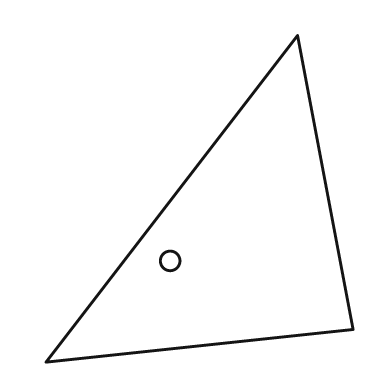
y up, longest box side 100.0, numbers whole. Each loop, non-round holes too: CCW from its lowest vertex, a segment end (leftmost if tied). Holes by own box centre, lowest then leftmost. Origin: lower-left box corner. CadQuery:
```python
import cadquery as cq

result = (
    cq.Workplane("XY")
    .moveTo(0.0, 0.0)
    .lineTo(94.0, 10.0)
    .lineTo(77.0, 100.0)
    .close()
    .moveTo(38.0, 31.0)
    .circle(3.0)
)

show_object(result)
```